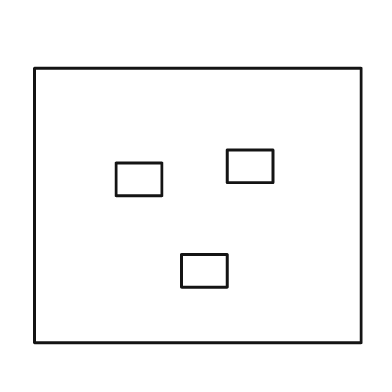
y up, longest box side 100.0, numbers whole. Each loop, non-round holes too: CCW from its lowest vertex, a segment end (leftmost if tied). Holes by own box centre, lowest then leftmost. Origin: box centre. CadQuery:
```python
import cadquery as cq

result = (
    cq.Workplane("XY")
    .moveTo(-50.0, -42.0)
    .lineTo(50.0, -42.0)
    .lineTo(50.0, 42.0)
    .lineTo(-50.0, 42.0)
    .close()
    .moveTo(-5.0, -25.0)
    .lineTo(9.0, -25.0)
    .lineTo(9.0, -15.0)
    .lineTo(-5.0, -15.0)
    .close()
    .moveTo(-25.0, 3.0)
    .lineTo(-11.0, 3.0)
    .lineTo(-11.0, 13.0)
    .lineTo(-25.0, 13.0)
    .close()
    .moveTo(9.0, 7.0)
    .lineTo(23.0, 7.0)
    .lineTo(23.0, 17.0)
    .lineTo(9.0, 17.0)
    .close()
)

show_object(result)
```